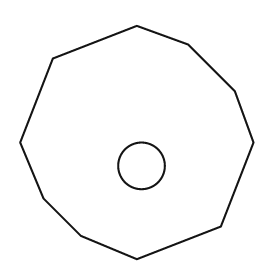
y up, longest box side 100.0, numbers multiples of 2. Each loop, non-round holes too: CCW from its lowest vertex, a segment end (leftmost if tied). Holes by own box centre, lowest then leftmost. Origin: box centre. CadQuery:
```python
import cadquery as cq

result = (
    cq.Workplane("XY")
    .moveTo(0.0, -50.0)
    .lineTo(36.0, -36.0)
    .lineTo(50.0, 0.0)
    .lineTo(42.0, 22.0)
    .lineTo(22.0, 42.0)
    .lineTo(0.0, 50.0)
    .lineTo(-36.0, 36.0)
    .lineTo(-50.0, 0.0)
    .lineTo(-40.0, -24.0)
    .lineTo(-24.0, -40.0)
    .close()
    .moveTo(2.0, -10.0)
    .circle(10.0)
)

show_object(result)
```